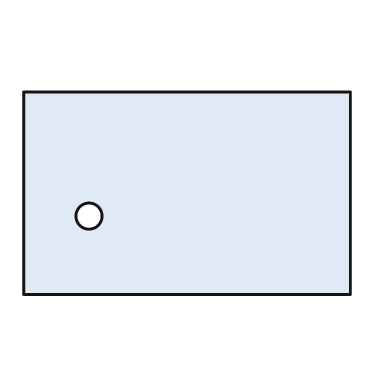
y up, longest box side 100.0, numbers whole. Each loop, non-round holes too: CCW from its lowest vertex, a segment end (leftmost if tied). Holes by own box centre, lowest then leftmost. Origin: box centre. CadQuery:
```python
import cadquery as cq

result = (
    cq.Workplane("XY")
    .moveTo(-50.0, -31.0)
    .lineTo(50.0, -31.0)
    .lineTo(50.0, 31.0)
    .lineTo(-50.0, 31.0)
    .close()
    .moveTo(-30.0, -7.0)
    .circle(4.0)
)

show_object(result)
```